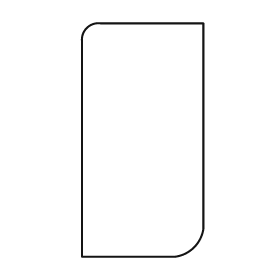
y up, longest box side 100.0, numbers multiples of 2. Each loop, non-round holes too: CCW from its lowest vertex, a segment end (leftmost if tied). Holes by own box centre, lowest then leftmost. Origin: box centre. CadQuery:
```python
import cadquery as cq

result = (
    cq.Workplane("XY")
    .moveTo(-26.0, -50.0)
    .lineTo(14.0, -50.0)
    .threePointArc((22.0, -46.0), (26.0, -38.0))
    .lineTo(26.0, 50.0)
    .lineTo(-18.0, 50.0)
    .threePointArc((-24.0, 48.0), (-26.0, 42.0))
    .close()
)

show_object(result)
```